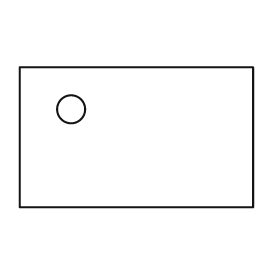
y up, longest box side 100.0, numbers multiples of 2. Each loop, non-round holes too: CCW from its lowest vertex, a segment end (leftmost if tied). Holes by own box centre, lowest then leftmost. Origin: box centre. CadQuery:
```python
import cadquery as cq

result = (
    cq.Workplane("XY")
    .moveTo(-50.0, -30.0)
    .lineTo(50.0, -30.0)
    .lineTo(50.0, 30.0)
    .lineTo(-50.0, 30.0)
    .close()
    .moveTo(-28.0, 12.0)
    .circle(6.0)
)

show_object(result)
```